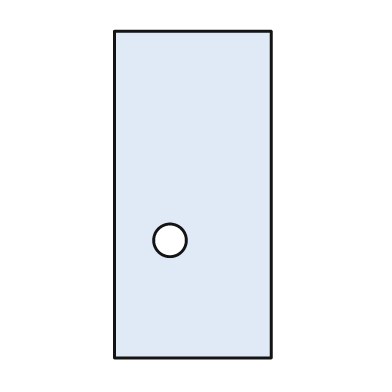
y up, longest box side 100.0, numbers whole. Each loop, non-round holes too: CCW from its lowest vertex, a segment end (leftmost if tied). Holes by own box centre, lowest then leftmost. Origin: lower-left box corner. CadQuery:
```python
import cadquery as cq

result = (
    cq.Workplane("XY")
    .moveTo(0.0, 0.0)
    .lineTo(48.0, 0.0)
    .lineTo(48.0, 100.0)
    .lineTo(0.0, 100.0)
    .close()
    .moveTo(17.0, 36.0)
    .circle(5.0)
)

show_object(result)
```